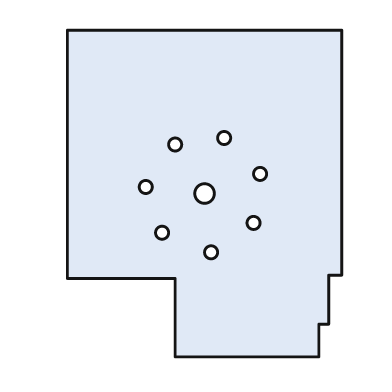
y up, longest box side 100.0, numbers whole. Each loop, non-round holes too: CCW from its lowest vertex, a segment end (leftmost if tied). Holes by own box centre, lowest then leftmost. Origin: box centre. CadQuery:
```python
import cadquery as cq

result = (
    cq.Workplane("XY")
    .moveTo(-9.0, -50.0)
    .lineTo(35.0, -50.0)
    .lineTo(35.0, -40.0)
    .lineTo(38.0, -40.0)
    .lineTo(38.0, -25.0)
    .lineTo(42.0, -25.0)
    .lineTo(42.0, 50.0)
    .lineTo(-42.0, 50.0)
    .lineTo(-42.0, -26.0)
    .lineTo(-9.0, -26.0)
    .close()
    .moveTo(2.0, -18.0)
    .circle(2.0)
    .moveTo(-13.0, -12.0)
    .circle(2.0)
    .moveTo(15.0, -9.0)
    .circle(2.0)
    .moveTo(0.0, 0.0)
    .circle(3.0)
    .moveTo(-18.0, 2.0)
    .circle(2.0)
    .moveTo(17.0, 6.0)
    .circle(2.0)
    .moveTo(-9.0, 15.0)
    .circle(2.0)
    .moveTo(6.0, 17.0)
    .circle(2.0)
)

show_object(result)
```